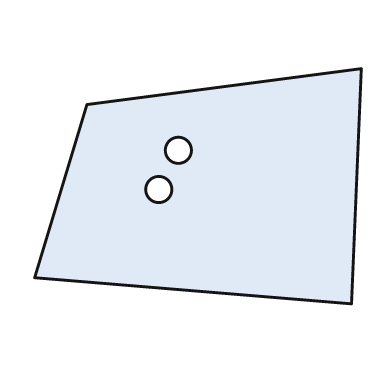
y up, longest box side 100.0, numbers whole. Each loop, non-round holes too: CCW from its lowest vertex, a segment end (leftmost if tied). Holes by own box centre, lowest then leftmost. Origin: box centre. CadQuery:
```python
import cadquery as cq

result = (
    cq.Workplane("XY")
    .moveTo(47.0, -36.0)
    .lineTo(50.0, 36.0)
    .lineTo(-34.0, 25.0)
    .lineTo(-50.0, -28.0)
    .close()
    .moveTo(-12.0, -1.0)
    .circle(4.0)
    .moveTo(-6.0, 11.0)
    .circle(4.0)
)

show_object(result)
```